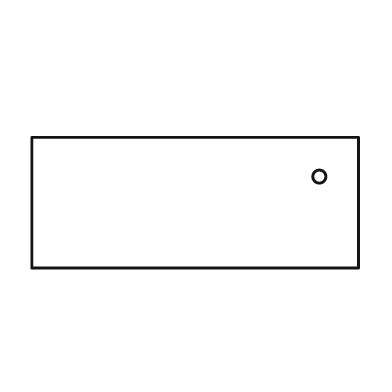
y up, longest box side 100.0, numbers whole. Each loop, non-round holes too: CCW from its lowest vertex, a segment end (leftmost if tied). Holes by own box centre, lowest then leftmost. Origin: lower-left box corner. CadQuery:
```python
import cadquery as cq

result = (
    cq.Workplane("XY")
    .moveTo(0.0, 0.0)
    .lineTo(100.0, 0.0)
    .lineTo(100.0, 40.0)
    .lineTo(0.0, 40.0)
    .close()
    .moveTo(88.0, 28.0)
    .circle(2.0)
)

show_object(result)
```